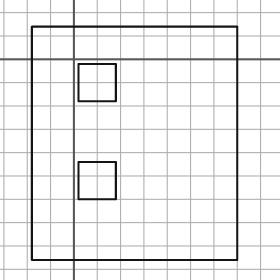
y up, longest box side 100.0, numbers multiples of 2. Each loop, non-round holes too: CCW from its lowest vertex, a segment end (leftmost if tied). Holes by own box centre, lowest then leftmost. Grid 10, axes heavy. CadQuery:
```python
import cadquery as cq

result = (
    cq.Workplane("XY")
    .moveTo(-18.0, -86.0)
    .lineTo(70.0, -86.0)
    .lineTo(70.0, 14.0)
    .lineTo(-18.0, 14.0)
    .close()
    .moveTo(2.0, -60.0)
    .lineTo(18.0, -60.0)
    .lineTo(18.0, -44.0)
    .lineTo(2.0, -44.0)
    .close()
    .moveTo(2.0, -18.0)
    .lineTo(18.0, -18.0)
    .lineTo(18.0, -2.0)
    .lineTo(2.0, -2.0)
    .close()
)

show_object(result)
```